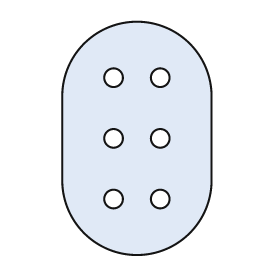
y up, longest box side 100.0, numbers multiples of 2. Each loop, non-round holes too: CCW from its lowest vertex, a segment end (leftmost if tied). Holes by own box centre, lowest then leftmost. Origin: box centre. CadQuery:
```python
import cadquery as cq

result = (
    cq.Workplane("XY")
    .moveTo(-32.0, -18.0)
    .threePointArc((0.0, -50.0), (32.0, -18.0))
    .lineTo(32.0, 18.0)
    .threePointArc((0.0, 50.0), (-32.0, 18.0))
    .close()
    .moveTo(-10.0, -26.0)
    .circle(4.0)
    .moveTo(10.0, -26.0)
    .circle(4.0)
    .moveTo(-10.0, 0.0)
    .circle(4.0)
    .moveTo(10.0, 0.0)
    .circle(4.0)
    .moveTo(-10.0, 26.0)
    .circle(4.0)
    .moveTo(10.0, 26.0)
    .circle(4.0)
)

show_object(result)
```